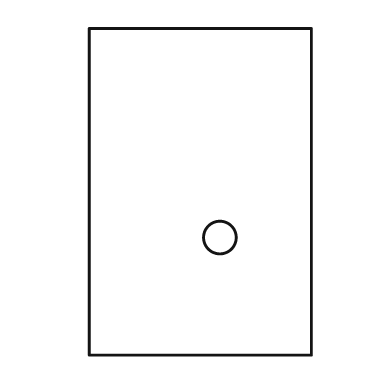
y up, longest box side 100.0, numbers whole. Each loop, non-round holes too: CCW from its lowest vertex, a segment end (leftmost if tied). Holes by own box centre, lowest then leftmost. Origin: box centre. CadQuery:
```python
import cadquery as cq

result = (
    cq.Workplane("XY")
    .moveTo(-34.0, -50.0)
    .lineTo(34.0, -50.0)
    .lineTo(34.0, 50.0)
    .lineTo(-34.0, 50.0)
    .close()
    .moveTo(6.0, -14.0)
    .circle(5.0)
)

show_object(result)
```